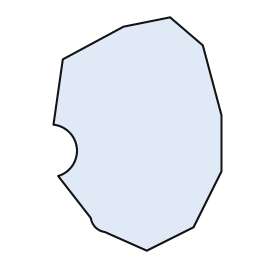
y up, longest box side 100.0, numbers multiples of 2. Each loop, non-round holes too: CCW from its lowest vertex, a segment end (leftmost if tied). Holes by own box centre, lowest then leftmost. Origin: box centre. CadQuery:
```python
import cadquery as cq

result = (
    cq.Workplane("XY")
    .moveTo(4.0, -50.0)
    .lineTo(24.0, -40.0)
    .lineTo(36.0, -16.0)
    .lineTo(36.0, 8.0)
    .lineTo(28.0, 38.0)
    .lineTo(14.0, 50.0)
    .lineTo(-6.0, 46.0)
    .lineTo(-32.0, 32.0)
    .lineTo(-36.0, 4.0)
    .threePointArc((-26.0, -6.0), (-34.0, -18.0))
    .lineTo(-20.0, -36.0)
    .threePointArc((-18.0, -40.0), (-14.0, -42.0))
    .close()
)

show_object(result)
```